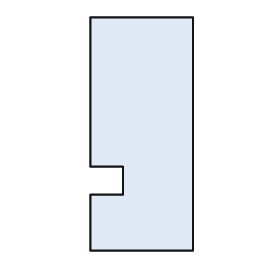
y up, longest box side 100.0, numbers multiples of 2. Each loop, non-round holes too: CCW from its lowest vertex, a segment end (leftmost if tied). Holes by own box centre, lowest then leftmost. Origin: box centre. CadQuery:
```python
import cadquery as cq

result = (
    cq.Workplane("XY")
    .moveTo(-22.0, -50.0)
    .lineTo(22.0, -50.0)
    .lineTo(22.0, 50.0)
    .lineTo(-22.0, 50.0)
    .lineTo(-22.0, -14.0)
    .lineTo(-8.0, -14.0)
    .lineTo(-8.0, -26.0)
    .lineTo(-22.0, -26.0)
    .close()
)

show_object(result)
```